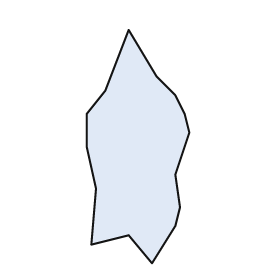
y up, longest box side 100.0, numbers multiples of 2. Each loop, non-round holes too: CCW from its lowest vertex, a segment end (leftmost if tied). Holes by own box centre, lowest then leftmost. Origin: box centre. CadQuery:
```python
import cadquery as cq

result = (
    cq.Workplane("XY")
    .moveTo(6.0, -50.0)
    .lineTo(16.0, -34.0)
    .lineTo(18.0, -26.0)
    .lineTo(16.0, -12.0)
    .lineTo(22.0, 6.0)
    .lineTo(20.0, 14.0)
    .lineTo(16.0, 22.0)
    .lineTo(8.0, 30.0)
    .lineTo(-4.0, 50.0)
    .lineTo(-14.0, 24.0)
    .lineTo(-22.0, 14.0)
    .lineTo(-22.0, 0.0)
    .lineTo(-18.0, -18.0)
    .lineTo(-20.0, -42.0)
    .lineTo(-4.0, -38.0)
    .close()
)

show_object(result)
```